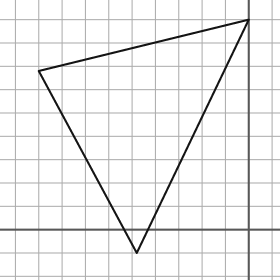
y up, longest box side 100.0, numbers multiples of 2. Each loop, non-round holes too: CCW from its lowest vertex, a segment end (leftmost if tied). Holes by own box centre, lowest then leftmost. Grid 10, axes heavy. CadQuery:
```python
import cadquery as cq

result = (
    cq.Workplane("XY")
    .moveTo(-48.0, -10.0)
    .lineTo(0.0, 90.0)
    .lineTo(-90.0, 68.0)
    .close()
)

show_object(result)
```